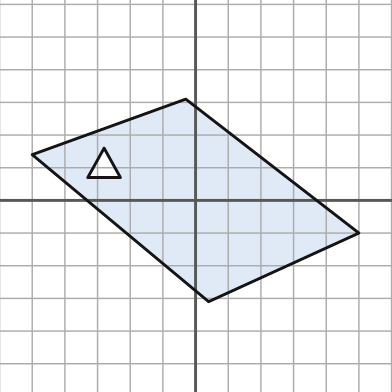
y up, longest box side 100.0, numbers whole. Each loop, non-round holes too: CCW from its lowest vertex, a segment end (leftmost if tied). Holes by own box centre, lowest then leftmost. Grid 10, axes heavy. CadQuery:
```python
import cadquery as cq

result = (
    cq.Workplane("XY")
    .moveTo(4.0, -31.0)
    .lineTo(50.0, -10.0)
    .lineTo(-3.0, 31.0)
    .lineTo(-50.0, 14.0)
    .close()
    .moveTo(-33.0, 7.0)
    .lineTo(-23.0, 7.0)
    .lineTo(-28.0, 16.0)
    .close()
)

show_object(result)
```